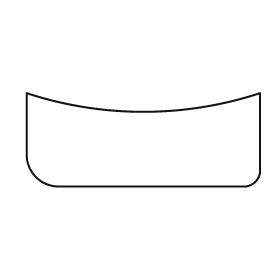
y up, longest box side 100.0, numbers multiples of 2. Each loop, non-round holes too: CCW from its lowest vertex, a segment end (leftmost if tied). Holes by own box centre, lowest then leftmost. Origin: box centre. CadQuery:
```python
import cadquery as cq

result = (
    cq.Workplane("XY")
    .moveTo(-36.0, -20.0)
    .lineTo(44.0, -20.0)
    .threePointArc((48.0, -18.0), (50.0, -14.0))
    .lineTo(50.0, 20.0)
    .threePointArc((0.0, 12.0), (-50.0, 20.0))
    .lineTo(-50.0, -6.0)
    .threePointArc((-46.0, -16.0), (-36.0, -20.0))
    .close()
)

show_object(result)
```